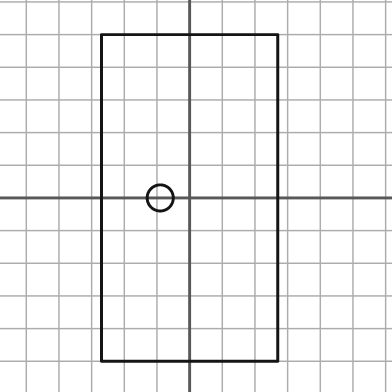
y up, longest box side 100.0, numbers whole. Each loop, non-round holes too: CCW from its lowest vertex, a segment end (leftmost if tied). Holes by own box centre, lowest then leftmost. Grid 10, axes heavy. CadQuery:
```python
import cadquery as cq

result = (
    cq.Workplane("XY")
    .moveTo(-27.0, -50.0)
    .lineTo(27.0, -50.0)
    .lineTo(27.0, 50.0)
    .lineTo(-27.0, 50.0)
    .close()
    .moveTo(-9.0, 0.0)
    .circle(4.0)
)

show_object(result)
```